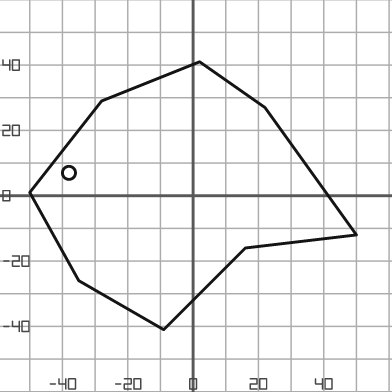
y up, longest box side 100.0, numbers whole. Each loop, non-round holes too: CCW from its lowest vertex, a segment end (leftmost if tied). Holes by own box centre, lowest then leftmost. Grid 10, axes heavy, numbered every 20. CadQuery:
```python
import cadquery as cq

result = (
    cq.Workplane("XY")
    .moveTo(-9.0, -41.0)
    .lineTo(16.0, -16.0)
    .lineTo(50.0, -12.0)
    .lineTo(22.0, 27.0)
    .lineTo(2.0, 41.0)
    .lineTo(-28.0, 29.0)
    .lineTo(-50.0, 1.0)
    .lineTo(-35.0, -26.0)
    .close()
    .moveTo(-38.0, 7.0)
    .circle(2.0)
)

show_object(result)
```